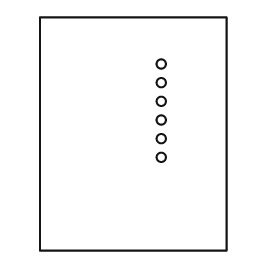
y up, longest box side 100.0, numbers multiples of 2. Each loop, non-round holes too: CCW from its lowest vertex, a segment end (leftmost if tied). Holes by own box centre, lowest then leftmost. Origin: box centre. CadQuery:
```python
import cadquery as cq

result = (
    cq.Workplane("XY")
    .moveTo(-40.0, -50.0)
    .lineTo(40.0, -50.0)
    .lineTo(40.0, 50.0)
    .lineTo(-40.0, 50.0)
    .close()
    .moveTo(12.0, -10.0)
    .circle(2.0)
    .moveTo(12.0, -2.0)
    .circle(2.0)
    .moveTo(12.0, 6.0)
    .circle(2.0)
    .moveTo(12.0, 14.0)
    .circle(2.0)
    .moveTo(12.0, 22.0)
    .circle(2.0)
    .moveTo(12.0, 30.0)
    .circle(2.0)
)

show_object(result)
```